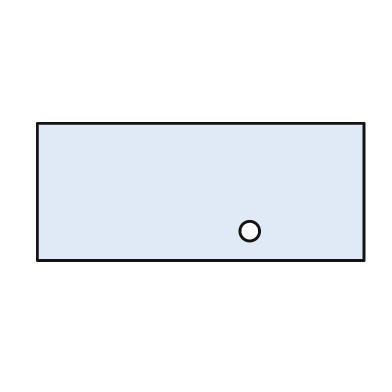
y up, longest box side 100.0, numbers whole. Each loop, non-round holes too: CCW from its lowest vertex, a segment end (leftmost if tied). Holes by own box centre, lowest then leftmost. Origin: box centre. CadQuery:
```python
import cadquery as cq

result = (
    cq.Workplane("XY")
    .moveTo(-50.0, -21.0)
    .lineTo(50.0, -21.0)
    .lineTo(50.0, 21.0)
    .lineTo(-50.0, 21.0)
    .close()
    .moveTo(15.0, -12.0)
    .circle(3.0)
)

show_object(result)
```